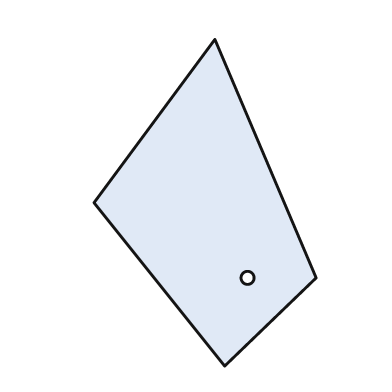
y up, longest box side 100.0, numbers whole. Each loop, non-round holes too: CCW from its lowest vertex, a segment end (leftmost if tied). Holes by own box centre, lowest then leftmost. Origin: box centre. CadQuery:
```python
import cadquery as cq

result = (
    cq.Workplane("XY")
    .moveTo(6.0, -50.0)
    .lineTo(34.0, -23.0)
    .lineTo(3.0, 50.0)
    .lineTo(-34.0, 0.0)
    .close()
    .moveTo(13.0, -23.0)
    .circle(2.0)
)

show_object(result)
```